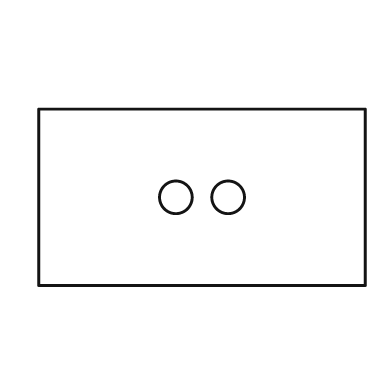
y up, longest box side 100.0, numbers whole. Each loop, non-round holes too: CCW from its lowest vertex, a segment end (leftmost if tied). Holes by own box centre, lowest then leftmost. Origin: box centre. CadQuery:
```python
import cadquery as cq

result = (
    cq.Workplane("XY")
    .moveTo(-50.0, -27.0)
    .lineTo(50.0, -27.0)
    .lineTo(50.0, 27.0)
    .lineTo(-50.0, 27.0)
    .close()
    .moveTo(-8.0, 0.0)
    .circle(5.0)
    .moveTo(8.0, 0.0)
    .circle(5.0)
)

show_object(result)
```